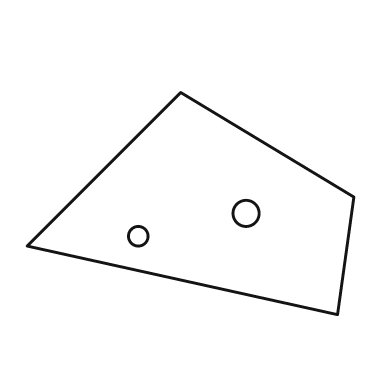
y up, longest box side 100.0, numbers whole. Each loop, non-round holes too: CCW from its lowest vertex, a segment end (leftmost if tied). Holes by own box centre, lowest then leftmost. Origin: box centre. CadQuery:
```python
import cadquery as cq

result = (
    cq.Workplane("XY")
    .moveTo(45.0, -34.0)
    .lineTo(50.0, 2.0)
    .lineTo(-3.0, 34.0)
    .lineTo(-50.0, -13.0)
    .close()
    .moveTo(-16.0, -10.0)
    .circle(3.0)
    .moveTo(17.0, -3.0)
    .circle(4.0)
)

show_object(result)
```